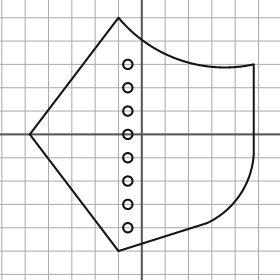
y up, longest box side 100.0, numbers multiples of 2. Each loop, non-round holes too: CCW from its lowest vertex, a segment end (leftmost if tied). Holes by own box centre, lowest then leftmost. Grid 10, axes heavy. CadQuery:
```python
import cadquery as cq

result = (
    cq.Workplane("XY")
    .moveTo(-10.0, -50.0)
    .lineTo(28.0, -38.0)
    .threePointArc((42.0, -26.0), (48.0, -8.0))
    .lineTo(48.0, 30.0)
    .threePointArc((16.0, 32.0), (-10.0, 50.0))
    .lineTo(-48.0, 0.0)
    .close()
    .moveTo(-6.0, -40.0)
    .circle(2.0)
    .moveTo(-6.0, -30.0)
    .circle(2.0)
    .moveTo(-6.0, -20.0)
    .circle(2.0)
    .moveTo(-6.0, -10.0)
    .circle(2.0)
    .moveTo(-6.0, 0.0)
    .circle(2.0)
    .moveTo(-6.0, 10.0)
    .circle(2.0)
    .moveTo(-6.0, 20.0)
    .circle(2.0)
    .moveTo(-6.0, 30.0)
    .circle(2.0)
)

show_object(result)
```